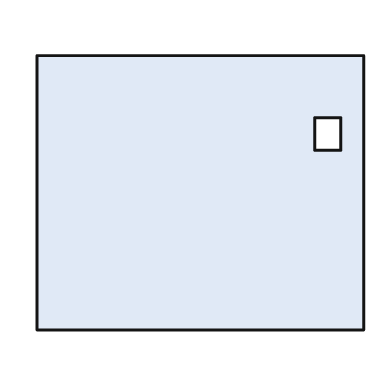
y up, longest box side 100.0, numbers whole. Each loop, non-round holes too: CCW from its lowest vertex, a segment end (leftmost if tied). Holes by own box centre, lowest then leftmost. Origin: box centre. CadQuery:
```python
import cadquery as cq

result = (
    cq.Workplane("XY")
    .moveTo(-50.0, -42.0)
    .lineTo(50.0, -42.0)
    .lineTo(50.0, 42.0)
    .lineTo(-50.0, 42.0)
    .close()
    .moveTo(35.0, 13.0)
    .lineTo(43.0, 13.0)
    .lineTo(43.0, 23.0)
    .lineTo(35.0, 23.0)
    .close()
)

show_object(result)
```